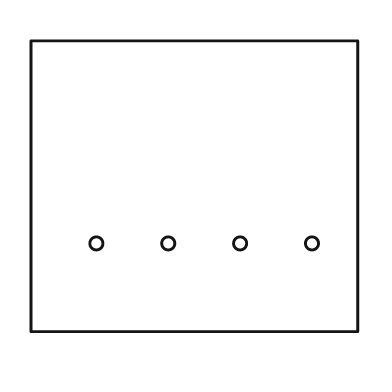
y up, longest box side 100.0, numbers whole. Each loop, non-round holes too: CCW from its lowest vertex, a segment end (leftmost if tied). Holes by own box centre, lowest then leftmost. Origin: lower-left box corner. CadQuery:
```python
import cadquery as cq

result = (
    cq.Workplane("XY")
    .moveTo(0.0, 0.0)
    .lineTo(100.0, 0.0)
    .lineTo(100.0, 89.0)
    .lineTo(0.0, 89.0)
    .close()
    .moveTo(20.0, 27.0)
    .circle(2.0)
    .moveTo(42.0, 27.0)
    .circle(2.0)
    .moveTo(64.0, 27.0)
    .circle(2.0)
    .moveTo(86.0, 27.0)
    .circle(2.0)
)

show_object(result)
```